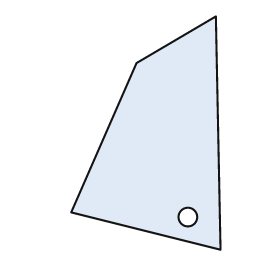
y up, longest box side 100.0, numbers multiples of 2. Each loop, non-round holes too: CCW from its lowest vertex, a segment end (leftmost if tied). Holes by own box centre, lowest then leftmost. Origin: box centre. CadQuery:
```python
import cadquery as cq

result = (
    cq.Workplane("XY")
    .moveTo(32.0, -50.0)
    .lineTo(30.0, 50.0)
    .lineTo(-4.0, 30.0)
    .lineTo(-32.0, -34.0)
    .close()
    .moveTo(18.0, -36.0)
    .circle(4.0)
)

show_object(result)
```